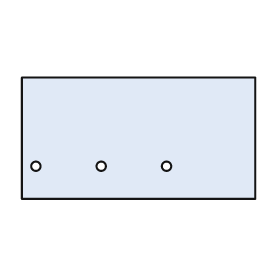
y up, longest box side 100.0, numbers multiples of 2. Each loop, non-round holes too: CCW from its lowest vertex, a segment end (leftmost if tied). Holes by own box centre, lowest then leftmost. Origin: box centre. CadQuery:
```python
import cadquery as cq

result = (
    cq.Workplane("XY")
    .moveTo(-50.0, -26.0)
    .lineTo(50.0, -26.0)
    .lineTo(50.0, 26.0)
    .lineTo(-50.0, 26.0)
    .close()
    .moveTo(-44.0, -12.0)
    .circle(2.0)
    .moveTo(-16.0, -12.0)
    .circle(2.0)
    .moveTo(12.0, -12.0)
    .circle(2.0)
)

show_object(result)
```